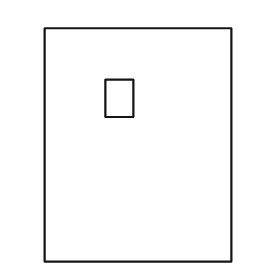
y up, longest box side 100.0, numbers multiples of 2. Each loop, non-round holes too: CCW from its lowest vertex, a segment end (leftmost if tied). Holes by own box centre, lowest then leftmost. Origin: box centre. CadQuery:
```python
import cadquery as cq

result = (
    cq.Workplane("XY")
    .moveTo(-40.0, -50.0)
    .lineTo(40.0, -50.0)
    .lineTo(40.0, 50.0)
    .lineTo(-40.0, 50.0)
    .close()
    .moveTo(-14.0, 12.0)
    .lineTo(-2.0, 12.0)
    .lineTo(-2.0, 28.0)
    .lineTo(-14.0, 28.0)
    .close()
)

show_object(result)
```